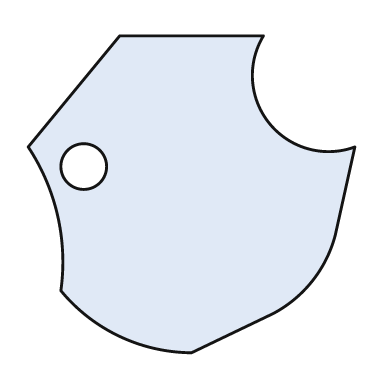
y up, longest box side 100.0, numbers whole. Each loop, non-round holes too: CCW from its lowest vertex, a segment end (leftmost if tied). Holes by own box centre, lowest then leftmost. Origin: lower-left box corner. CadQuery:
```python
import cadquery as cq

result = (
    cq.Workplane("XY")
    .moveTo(50.0, 0.0)
    .lineTo(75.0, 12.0)
    .threePointArc((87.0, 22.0), (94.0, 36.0))
    .lineTo(100.0, 63.0)
    .threePointArc((74.0, 70.0), (72.0, 97.0))
    .lineTo(28.0, 97.0)
    .lineTo(0.0, 63.0)
    .threePointArc((9.0, 42.0), (10.0, 19.0))
    .threePointArc((28.0, 5.0), (50.0, 0.0))
    .close()
    .moveTo(17.0, 57.0)
    .circle(7.0)
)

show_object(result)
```